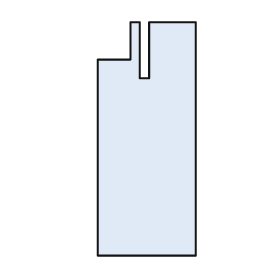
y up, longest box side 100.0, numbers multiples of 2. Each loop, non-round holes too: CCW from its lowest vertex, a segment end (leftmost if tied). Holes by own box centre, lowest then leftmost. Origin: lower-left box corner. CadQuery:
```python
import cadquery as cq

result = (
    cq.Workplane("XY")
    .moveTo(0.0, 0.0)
    .lineTo(42.0, 0.0)
    .lineTo(42.0, 100.0)
    .lineTo(22.0, 100.0)
    .lineTo(22.0, 76.0)
    .lineTo(18.0, 76.0)
    .lineTo(18.0, 100.0)
    .lineTo(14.0, 100.0)
    .lineTo(14.0, 84.0)
    .lineTo(0.0, 84.0)
    .close()
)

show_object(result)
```